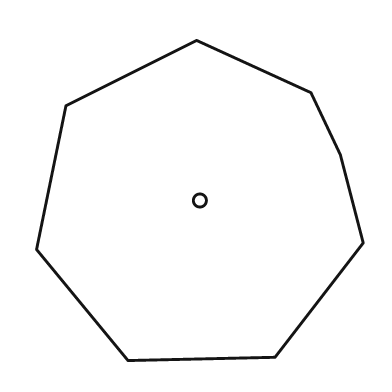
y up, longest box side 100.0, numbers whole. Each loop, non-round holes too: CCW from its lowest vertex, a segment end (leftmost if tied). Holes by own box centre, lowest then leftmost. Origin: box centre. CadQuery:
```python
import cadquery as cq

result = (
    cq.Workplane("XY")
    .moveTo(-22.0, -49.0)
    .lineTo(23.0, -48.0)
    .lineTo(50.0, -13.0)
    .lineTo(43.0, 14.0)
    .lineTo(34.0, 33.0)
    .lineTo(-1.0, 49.0)
    .lineTo(-41.0, 29.0)
    .lineTo(-50.0, -15.0)
    .close()
    .moveTo(0.0, 0.0)
    .circle(2.0)
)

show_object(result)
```